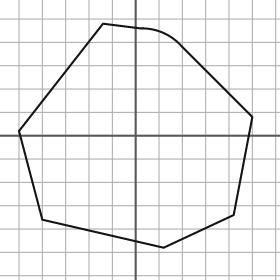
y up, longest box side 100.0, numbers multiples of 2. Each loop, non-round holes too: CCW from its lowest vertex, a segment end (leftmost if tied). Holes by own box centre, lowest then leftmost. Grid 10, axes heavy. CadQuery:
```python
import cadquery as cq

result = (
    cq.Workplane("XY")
    .moveTo(12.0, -48.0)
    .lineTo(42.0, -34.0)
    .lineTo(50.0, 8.0)
    .lineTo(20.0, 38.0)
    .threePointArc((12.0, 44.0), (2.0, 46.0))
    .lineTo(-14.0, 48.0)
    .lineTo(-50.0, 2.0)
    .lineTo(-40.0, -36.0)
    .close()
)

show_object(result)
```